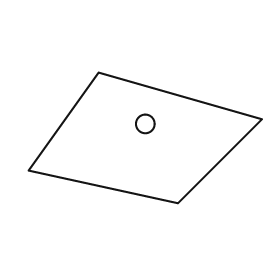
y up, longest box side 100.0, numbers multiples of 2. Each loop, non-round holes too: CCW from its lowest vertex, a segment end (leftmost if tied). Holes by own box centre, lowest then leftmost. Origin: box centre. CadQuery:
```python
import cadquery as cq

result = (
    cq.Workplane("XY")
    .moveTo(14.0, -28.0)
    .lineTo(50.0, 8.0)
    .lineTo(-20.0, 28.0)
    .lineTo(-50.0, -14.0)
    .close()
    .moveTo(0.0, 6.0)
    .circle(4.0)
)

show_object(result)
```